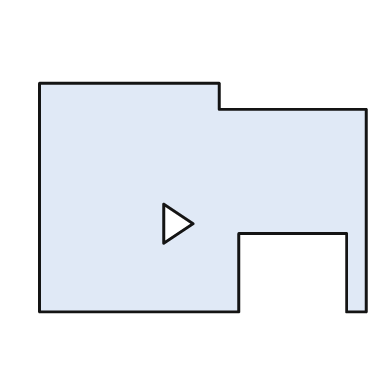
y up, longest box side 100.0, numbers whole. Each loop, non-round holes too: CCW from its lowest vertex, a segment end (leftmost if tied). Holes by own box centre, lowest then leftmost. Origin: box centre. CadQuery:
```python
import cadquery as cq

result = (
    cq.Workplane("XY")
    .moveTo(-50.0, -35.0)
    .lineTo(11.0, -35.0)
    .lineTo(11.0, -11.0)
    .lineTo(44.0, -11.0)
    .lineTo(44.0, -35.0)
    .lineTo(50.0, -35.0)
    .lineTo(50.0, 27.0)
    .lineTo(5.0, 27.0)
    .lineTo(5.0, 35.0)
    .lineTo(-50.0, 35.0)
    .close()
    .moveTo(-12.0, -14.0)
    .lineTo(-3.0, -8.0)
    .lineTo(-12.0, -2.0)
    .close()
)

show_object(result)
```